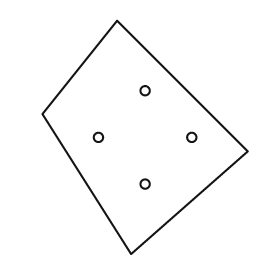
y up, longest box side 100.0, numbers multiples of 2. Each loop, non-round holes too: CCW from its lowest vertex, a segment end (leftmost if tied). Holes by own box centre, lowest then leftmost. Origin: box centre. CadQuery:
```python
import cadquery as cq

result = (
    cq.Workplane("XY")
    .moveTo(-6.0, -50.0)
    .lineTo(44.0, -6.0)
    .lineTo(-12.0, 50.0)
    .lineTo(-44.0, 10.0)
    .close()
    .moveTo(0.0, -20.0)
    .circle(2.0)
    .moveTo(-20.0, 0.0)
    .circle(2.0)
    .moveTo(20.0, 0.0)
    .circle(2.0)
    .moveTo(0.0, 20.0)
    .circle(2.0)
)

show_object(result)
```